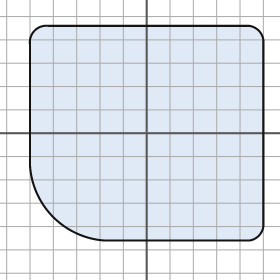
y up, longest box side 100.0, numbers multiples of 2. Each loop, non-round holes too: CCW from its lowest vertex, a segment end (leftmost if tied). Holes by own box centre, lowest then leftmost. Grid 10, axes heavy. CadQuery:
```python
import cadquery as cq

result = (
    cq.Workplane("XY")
    .moveTo(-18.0, -46.0)
    .lineTo(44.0, -46.0)
    .threePointArc((48.0, -44.0), (50.0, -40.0))
    .lineTo(50.0, 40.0)
    .threePointArc((48.0, 44.0), (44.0, 46.0))
    .lineTo(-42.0, 46.0)
    .threePointArc((-48.0, 44.0), (-50.0, 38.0))
    .lineTo(-50.0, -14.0)
    .threePointArc((-40.0, -36.0), (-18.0, -46.0))
    .close()
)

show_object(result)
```